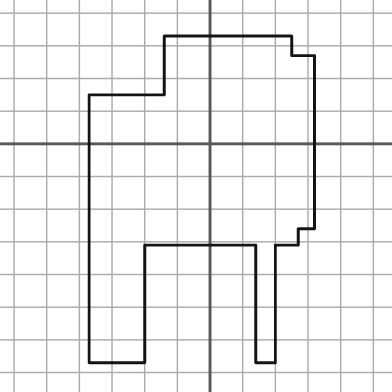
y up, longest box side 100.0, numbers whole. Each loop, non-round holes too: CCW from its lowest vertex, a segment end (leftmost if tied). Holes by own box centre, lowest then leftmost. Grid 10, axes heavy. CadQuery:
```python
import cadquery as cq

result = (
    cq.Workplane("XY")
    .moveTo(-37.0, -67.0)
    .lineTo(-20.0, -67.0)
    .lineTo(-20.0, -31.0)
    .lineTo(14.0, -31.0)
    .lineTo(14.0, -67.0)
    .lineTo(20.0, -67.0)
    .lineTo(20.0, -31.0)
    .lineTo(27.0, -31.0)
    .lineTo(27.0, -26.0)
    .lineTo(32.0, -26.0)
    .lineTo(32.0, 27.0)
    .lineTo(25.0, 27.0)
    .lineTo(25.0, 33.0)
    .lineTo(-14.0, 33.0)
    .lineTo(-14.0, 15.0)
    .lineTo(-37.0, 15.0)
    .close()
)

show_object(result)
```